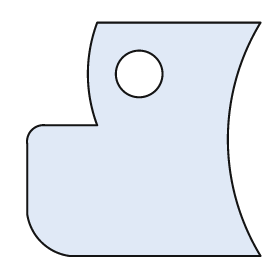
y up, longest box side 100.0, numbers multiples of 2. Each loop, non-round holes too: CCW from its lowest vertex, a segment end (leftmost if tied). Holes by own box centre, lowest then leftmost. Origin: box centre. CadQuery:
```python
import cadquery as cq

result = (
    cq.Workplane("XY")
    .moveTo(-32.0, -50.0)
    .lineTo(50.0, -50.0)
    .threePointArc((36.0, 0.0), (50.0, 50.0))
    .lineTo(-20.0, 50.0)
    .threePointArc((-24.0, 28.0), (-20.0, 6.0))
    .lineTo(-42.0, 6.0)
    .threePointArc((-48.0, 4.0), (-50.0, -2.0))
    .lineTo(-50.0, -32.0)
    .threePointArc((-44.0, -44.0), (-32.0, -50.0))
    .close()
    .moveTo(-2.0, 28.0)
    .circle(10.0)
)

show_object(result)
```